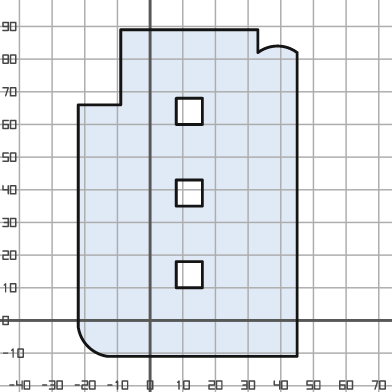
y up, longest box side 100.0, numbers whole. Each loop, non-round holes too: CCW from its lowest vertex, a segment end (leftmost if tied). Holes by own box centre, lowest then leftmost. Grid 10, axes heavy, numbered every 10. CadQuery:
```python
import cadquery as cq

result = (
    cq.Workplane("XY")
    .moveTo(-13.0, -11.0)
    .lineTo(45.0, -11.0)
    .lineTo(45.0, 82.0)
    .threePointArc((39.0, 84.0), (33.0, 82.0))
    .lineTo(33.0, 89.0)
    .lineTo(-9.0, 89.0)
    .lineTo(-9.0, 66.0)
    .lineTo(-22.0, 66.0)
    .lineTo(-22.0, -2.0)
    .threePointArc((-19.0, -8.0), (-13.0, -11.0))
    .close()
    .moveTo(8.0, 10.0)
    .lineTo(16.0, 10.0)
    .lineTo(16.0, 18.0)
    .lineTo(8.0, 18.0)
    .close()
    .moveTo(8.0, 35.0)
    .lineTo(16.0, 35.0)
    .lineTo(16.0, 43.0)
    .lineTo(8.0, 43.0)
    .close()
    .moveTo(8.0, 60.0)
    .lineTo(16.0, 60.0)
    .lineTo(16.0, 68.0)
    .lineTo(8.0, 68.0)
    .close()
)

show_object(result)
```